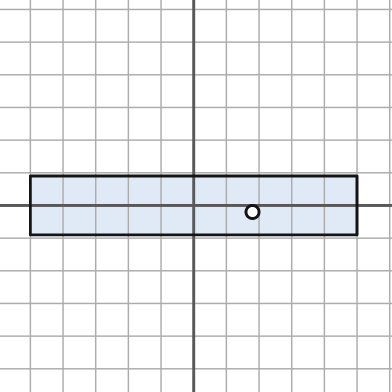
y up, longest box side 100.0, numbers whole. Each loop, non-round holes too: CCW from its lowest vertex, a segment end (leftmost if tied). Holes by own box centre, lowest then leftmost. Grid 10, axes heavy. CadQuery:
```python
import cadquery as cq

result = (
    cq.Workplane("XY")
    .moveTo(-50.0, -9.0)
    .lineTo(50.0, -9.0)
    .lineTo(50.0, 9.0)
    .lineTo(-50.0, 9.0)
    .close()
    .moveTo(18.0, -2.0)
    .circle(2.0)
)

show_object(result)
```